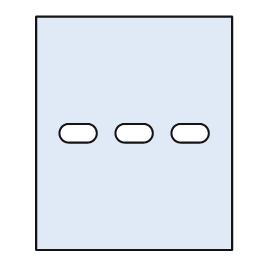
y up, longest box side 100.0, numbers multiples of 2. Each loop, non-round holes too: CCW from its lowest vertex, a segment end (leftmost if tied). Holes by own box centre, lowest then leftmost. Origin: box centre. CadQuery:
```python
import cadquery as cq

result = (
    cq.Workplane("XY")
    .moveTo(-42.0, -50.0)
    .lineTo(42.0, -50.0)
    .lineTo(42.0, 50.0)
    .lineTo(-42.0, 50.0)
    .close()
    .moveTo(-28.0, -4.0)
    .lineTo(-20.0, -4.0)
    .threePointArc((-16.0, 0.0), (-20.0, 4.0))
    .lineTo(-28.0, 4.0)
    .threePointArc((-32.0, 0.0), (-28.0, -4.0))
    .close()
    .moveTo(-4.0, -4.0)
    .lineTo(4.0, -4.0)
    .threePointArc((8.0, 0.0), (4.0, 4.0))
    .lineTo(-4.0, 4.0)
    .threePointArc((-8.0, 0.0), (-4.0, -4.0))
    .close()
    .moveTo(20.0, -4.0)
    .lineTo(28.0, -4.0)
    .threePointArc((32.0, 0.0), (28.0, 4.0))
    .lineTo(20.0, 4.0)
    .threePointArc((16.0, 0.0), (20.0, -4.0))
    .close()
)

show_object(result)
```